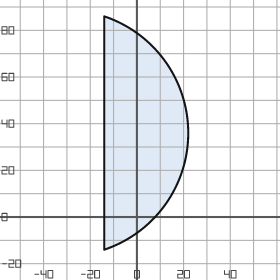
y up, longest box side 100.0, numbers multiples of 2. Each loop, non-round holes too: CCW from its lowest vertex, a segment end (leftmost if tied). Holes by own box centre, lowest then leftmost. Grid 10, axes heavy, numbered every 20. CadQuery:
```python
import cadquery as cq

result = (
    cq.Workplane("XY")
    .moveTo(-14.0, -14.0)
    .threePointArc((22.0, 36.0), (-14.0, 86.0))
    .close()
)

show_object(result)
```